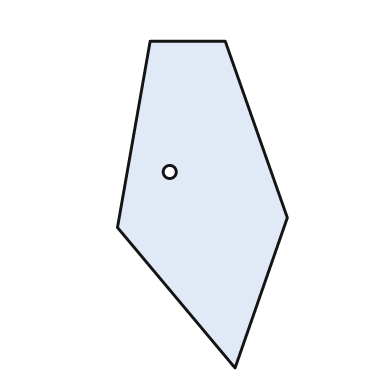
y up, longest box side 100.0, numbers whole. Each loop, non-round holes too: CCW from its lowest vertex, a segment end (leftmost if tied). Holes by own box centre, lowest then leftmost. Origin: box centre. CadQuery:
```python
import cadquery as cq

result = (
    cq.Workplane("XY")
    .moveTo(10.0, -50.0)
    .lineTo(26.0, -4.0)
    .lineTo(7.0, 50.0)
    .lineTo(-16.0, 50.0)
    .lineTo(-26.0, -7.0)
    .close()
    .moveTo(-10.0, 10.0)
    .circle(2.0)
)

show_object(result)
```